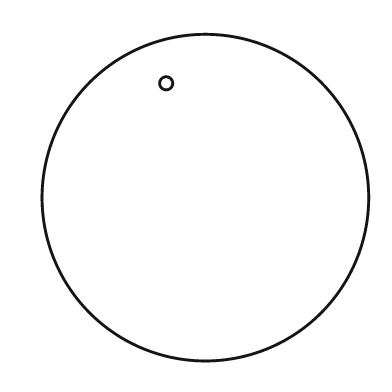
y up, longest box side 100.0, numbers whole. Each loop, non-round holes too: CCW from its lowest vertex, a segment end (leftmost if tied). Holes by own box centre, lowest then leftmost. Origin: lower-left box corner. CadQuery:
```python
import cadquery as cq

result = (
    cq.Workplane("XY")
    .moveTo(50.0, 50.0)
    .circle(50.0)
    .moveTo(38.0, 85.0)
    .circle(2.0)
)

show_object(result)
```